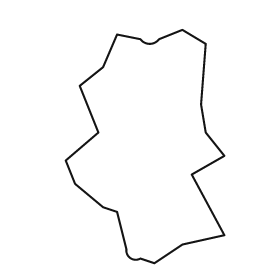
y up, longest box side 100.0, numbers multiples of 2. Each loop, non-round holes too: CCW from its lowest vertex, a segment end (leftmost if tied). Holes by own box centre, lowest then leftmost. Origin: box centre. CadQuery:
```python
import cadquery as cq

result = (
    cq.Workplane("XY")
    .moveTo(4.0, -50.0)
    .lineTo(16.0, -42.0)
    .lineTo(34.0, -38.0)
    .lineTo(20.0, -12.0)
    .lineTo(34.0, -4.0)
    .lineTo(26.0, 6.0)
    .lineTo(24.0, 18.0)
    .lineTo(26.0, 44.0)
    .lineTo(16.0, 50.0)
    .lineTo(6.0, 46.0)
    .threePointArc((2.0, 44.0), (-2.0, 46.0))
    .lineTo(-12.0, 48.0)
    .lineTo(-18.0, 34.0)
    .lineTo(-28.0, 26.0)
    .lineTo(-20.0, 6.0)
    .lineTo(-34.0, -6.0)
    .lineTo(-30.0, -16.0)
    .lineTo(-18.0, -26.0)
    .lineTo(-12.0, -28.0)
    .lineTo(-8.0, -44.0)
    .threePointArc((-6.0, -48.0), (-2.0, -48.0))
    .close()
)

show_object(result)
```